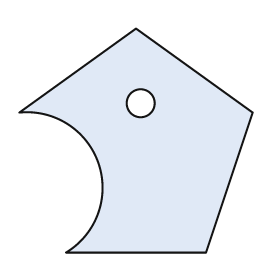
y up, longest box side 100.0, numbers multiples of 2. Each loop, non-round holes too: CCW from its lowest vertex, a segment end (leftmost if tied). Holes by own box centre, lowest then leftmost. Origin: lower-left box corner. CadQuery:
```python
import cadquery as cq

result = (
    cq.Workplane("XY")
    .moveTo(20.0, 0.0)
    .lineTo(80.0, 0.0)
    .lineTo(100.0, 60.0)
    .lineTo(50.0, 96.0)
    .lineTo(0.0, 60.0)
    .threePointArc((34.0, 38.0), (20.0, 0.0))
    .close()
    .moveTo(52.0, 64.0)
    .circle(6.0)
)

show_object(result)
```